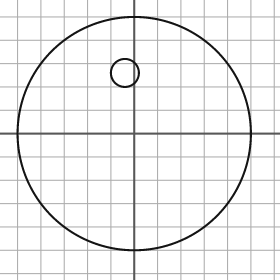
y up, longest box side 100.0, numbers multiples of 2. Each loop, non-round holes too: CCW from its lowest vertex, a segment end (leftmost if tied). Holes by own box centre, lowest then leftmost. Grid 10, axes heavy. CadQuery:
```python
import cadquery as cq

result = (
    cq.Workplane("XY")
    .moveTo(0.0, 0.0)
    .circle(50.0)
    .moveTo(-4.0, 26.0)
    .circle(6.0)
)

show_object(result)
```